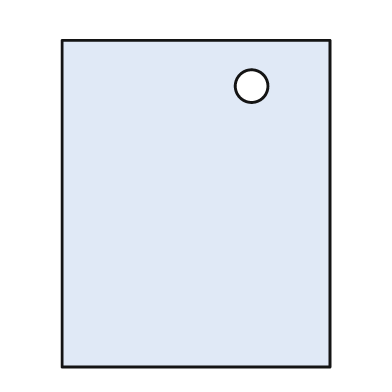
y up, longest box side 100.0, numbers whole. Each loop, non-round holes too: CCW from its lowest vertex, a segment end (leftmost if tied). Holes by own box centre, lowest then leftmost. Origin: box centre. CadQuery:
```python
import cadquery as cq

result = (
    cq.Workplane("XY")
    .moveTo(-41.0, -50.0)
    .lineTo(41.0, -50.0)
    .lineTo(41.0, 50.0)
    .lineTo(-41.0, 50.0)
    .close()
    .moveTo(17.0, 36.0)
    .circle(5.0)
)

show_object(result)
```